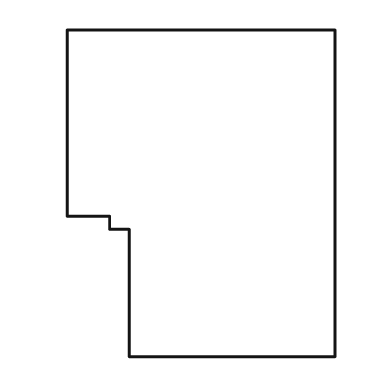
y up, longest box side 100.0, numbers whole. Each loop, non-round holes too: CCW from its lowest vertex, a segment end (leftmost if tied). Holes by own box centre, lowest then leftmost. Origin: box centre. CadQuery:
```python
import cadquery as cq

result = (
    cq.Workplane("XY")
    .moveTo(-22.0, -50.0)
    .lineTo(41.0, -50.0)
    .lineTo(41.0, 50.0)
    .lineTo(-41.0, 50.0)
    .lineTo(-41.0, -7.0)
    .lineTo(-28.0, -7.0)
    .lineTo(-28.0, -11.0)
    .lineTo(-22.0, -11.0)
    .close()
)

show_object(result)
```